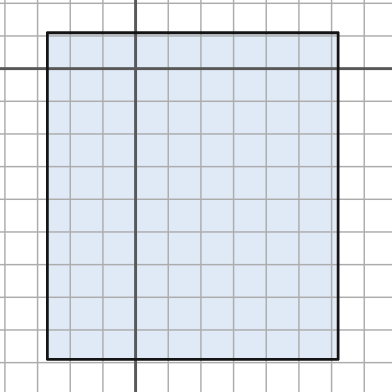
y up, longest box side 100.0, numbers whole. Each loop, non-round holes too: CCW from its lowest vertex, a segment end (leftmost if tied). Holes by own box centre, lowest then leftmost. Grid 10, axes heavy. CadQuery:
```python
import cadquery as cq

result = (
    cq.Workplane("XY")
    .moveTo(-27.0, -89.0)
    .lineTo(62.0, -89.0)
    .lineTo(62.0, 11.0)
    .lineTo(-27.0, 11.0)
    .close()
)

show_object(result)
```